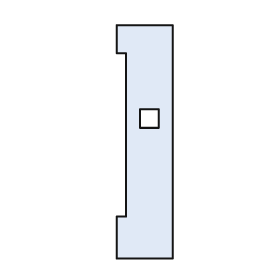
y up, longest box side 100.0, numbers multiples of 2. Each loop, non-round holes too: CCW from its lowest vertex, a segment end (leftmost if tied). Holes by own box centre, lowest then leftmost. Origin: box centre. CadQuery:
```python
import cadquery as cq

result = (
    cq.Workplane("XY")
    .moveTo(-12.0, -50.0)
    .lineTo(12.0, -50.0)
    .lineTo(12.0, 50.0)
    .lineTo(-12.0, 50.0)
    .lineTo(-12.0, 38.0)
    .lineTo(-8.0, 38.0)
    .lineTo(-8.0, -32.0)
    .lineTo(-12.0, -32.0)
    .close()
    .moveTo(-2.0, 6.0)
    .lineTo(6.0, 6.0)
    .lineTo(6.0, 14.0)
    .lineTo(-2.0, 14.0)
    .close()
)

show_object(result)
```